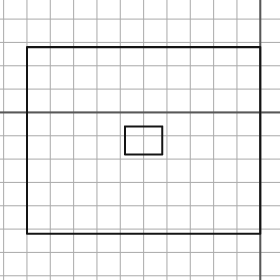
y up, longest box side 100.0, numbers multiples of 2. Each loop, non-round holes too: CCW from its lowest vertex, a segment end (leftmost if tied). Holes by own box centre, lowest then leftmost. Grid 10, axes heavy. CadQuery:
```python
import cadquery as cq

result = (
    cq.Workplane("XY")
    .moveTo(-100.0, -52.0)
    .lineTo(0.0, -52.0)
    .lineTo(0.0, 28.0)
    .lineTo(-100.0, 28.0)
    .close()
    .moveTo(-58.0, -18.0)
    .lineTo(-42.0, -18.0)
    .lineTo(-42.0, -6.0)
    .lineTo(-58.0, -6.0)
    .close()
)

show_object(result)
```